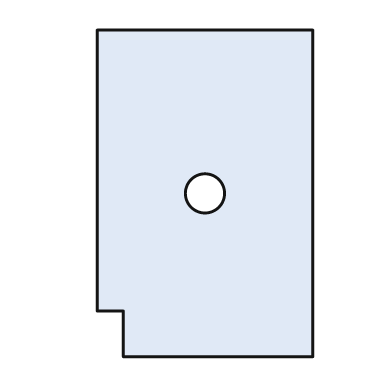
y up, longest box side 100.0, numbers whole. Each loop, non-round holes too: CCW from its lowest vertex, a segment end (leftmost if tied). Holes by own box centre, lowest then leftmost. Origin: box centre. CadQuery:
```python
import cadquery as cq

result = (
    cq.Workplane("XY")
    .moveTo(-25.0, -50.0)
    .lineTo(33.0, -50.0)
    .lineTo(33.0, 50.0)
    .lineTo(-33.0, 50.0)
    .lineTo(-33.0, -36.0)
    .lineTo(-25.0, -36.0)
    .close()
    .moveTo(0.0, 0.0)
    .circle(6.0)
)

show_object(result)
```